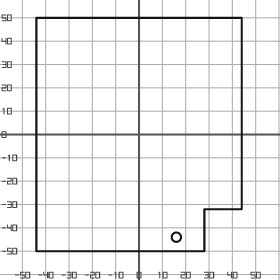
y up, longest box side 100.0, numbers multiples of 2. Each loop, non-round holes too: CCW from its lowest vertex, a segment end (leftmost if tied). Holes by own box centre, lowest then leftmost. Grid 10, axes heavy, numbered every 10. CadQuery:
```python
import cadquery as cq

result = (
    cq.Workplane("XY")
    .moveTo(-44.0, -50.0)
    .lineTo(28.0, -50.0)
    .lineTo(28.0, -32.0)
    .lineTo(44.0, -32.0)
    .lineTo(44.0, 50.0)
    .lineTo(-44.0, 50.0)
    .close()
    .moveTo(16.0, -44.0)
    .circle(2.0)
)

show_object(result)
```